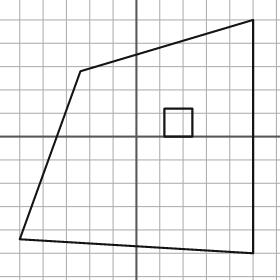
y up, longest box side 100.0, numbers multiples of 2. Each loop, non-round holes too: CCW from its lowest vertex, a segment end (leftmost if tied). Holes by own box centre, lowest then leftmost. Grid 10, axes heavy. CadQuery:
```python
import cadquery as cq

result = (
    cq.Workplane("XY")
    .moveTo(50.0, -50.0)
    .lineTo(50.0, 50.0)
    .lineTo(-24.0, 28.0)
    .lineTo(-50.0, -44.0)
    .close()
    .moveTo(12.0, 0.0)
    .lineTo(24.0, 0.0)
    .lineTo(24.0, 12.0)
    .lineTo(12.0, 12.0)
    .close()
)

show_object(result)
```